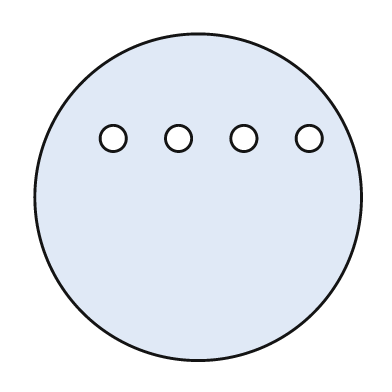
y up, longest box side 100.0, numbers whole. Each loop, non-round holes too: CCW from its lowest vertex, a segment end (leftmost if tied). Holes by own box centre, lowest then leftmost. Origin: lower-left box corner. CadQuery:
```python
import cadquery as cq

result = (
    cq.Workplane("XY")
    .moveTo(50.0, 50.0)
    .circle(50.0)
    .moveTo(24.0, 68.0)
    .circle(4.0)
    .moveTo(44.0, 68.0)
    .circle(4.0)
    .moveTo(64.0, 68.0)
    .circle(4.0)
    .moveTo(84.0, 68.0)
    .circle(4.0)
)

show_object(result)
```